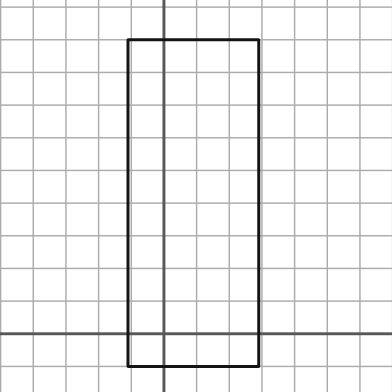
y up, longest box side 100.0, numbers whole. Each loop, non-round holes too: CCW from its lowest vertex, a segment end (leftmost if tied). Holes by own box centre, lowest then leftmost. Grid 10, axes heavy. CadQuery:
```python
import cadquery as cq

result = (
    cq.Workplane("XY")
    .moveTo(-11.0, -10.0)
    .lineTo(29.0, -10.0)
    .lineTo(29.0, 90.0)
    .lineTo(-11.0, 90.0)
    .close()
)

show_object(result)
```